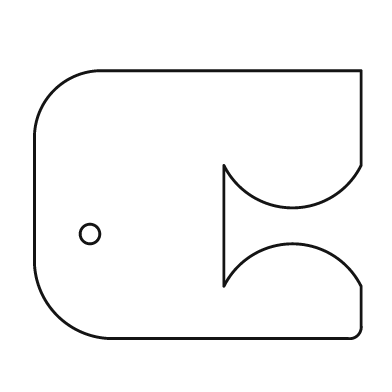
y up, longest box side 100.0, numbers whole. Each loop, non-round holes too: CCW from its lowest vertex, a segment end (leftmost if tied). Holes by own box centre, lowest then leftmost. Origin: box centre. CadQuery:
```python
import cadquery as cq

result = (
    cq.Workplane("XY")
    .moveTo(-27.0, -41.0)
    .lineTo(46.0, -41.0)
    .threePointArc((49.0, -40.0), (50.0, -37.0))
    .lineTo(50.0, -25.0)
    .threePointArc((29.0, -12.0), (8.0, -25.0))
    .lineTo(8.0, 12.0)
    .threePointArc((29.0, -1.0), (50.0, 12.0))
    .lineTo(50.0, 41.0)
    .lineTo(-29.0, 41.0)
    .threePointArc((-44.0, 35.0), (-50.0, 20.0))
    .lineTo(-50.0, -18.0)
    .threePointArc((-43.0, -34.0), (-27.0, -41.0))
    .close()
    .moveTo(-33.0, -9.0)
    .circle(3.0)
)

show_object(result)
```